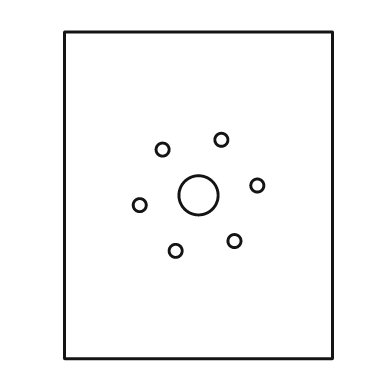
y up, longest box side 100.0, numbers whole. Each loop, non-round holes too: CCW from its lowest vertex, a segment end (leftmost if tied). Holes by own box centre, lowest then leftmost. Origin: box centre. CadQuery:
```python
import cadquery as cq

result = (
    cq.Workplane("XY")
    .moveTo(-41.0, -50.0)
    .lineTo(41.0, -50.0)
    .lineTo(41.0, 50.0)
    .lineTo(-41.0, 50.0)
    .close()
    .moveTo(-7.0, -17.0)
    .circle(2.0)
    .moveTo(11.0, -14.0)
    .circle(2.0)
    .moveTo(-18.0, -3.0)
    .circle(2.0)
    .moveTo(0.0, 0.0)
    .circle(6.0)
    .moveTo(18.0, 3.0)
    .circle(2.0)
    .moveTo(-11.0, 14.0)
    .circle(2.0)
    .moveTo(7.0, 17.0)
    .circle(2.0)
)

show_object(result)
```